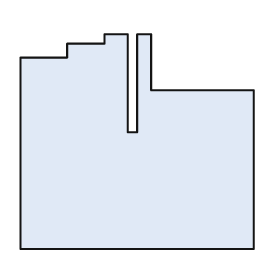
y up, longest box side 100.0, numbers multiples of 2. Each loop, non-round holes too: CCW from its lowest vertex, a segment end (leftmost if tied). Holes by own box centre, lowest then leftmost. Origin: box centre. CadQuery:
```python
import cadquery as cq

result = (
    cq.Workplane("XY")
    .moveTo(-50.0, -46.0)
    .lineTo(50.0, -46.0)
    .lineTo(50.0, 22.0)
    .lineTo(6.0, 22.0)
    .lineTo(6.0, 46.0)
    .lineTo(0.0, 46.0)
    .lineTo(0.0, 4.0)
    .lineTo(-4.0, 4.0)
    .lineTo(-4.0, 46.0)
    .lineTo(-14.0, 46.0)
    .lineTo(-14.0, 42.0)
    .lineTo(-30.0, 42.0)
    .lineTo(-30.0, 36.0)
    .lineTo(-50.0, 36.0)
    .close()
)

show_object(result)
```